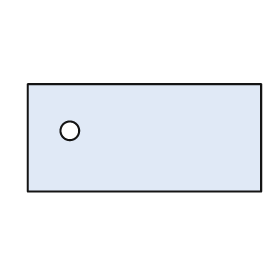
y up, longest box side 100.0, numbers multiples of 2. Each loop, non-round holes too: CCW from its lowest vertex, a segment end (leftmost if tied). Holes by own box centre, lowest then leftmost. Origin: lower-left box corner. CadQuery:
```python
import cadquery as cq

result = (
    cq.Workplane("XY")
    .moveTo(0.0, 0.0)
    .lineTo(100.0, 0.0)
    .lineTo(100.0, 46.0)
    .lineTo(0.0, 46.0)
    .close()
    .moveTo(18.0, 26.0)
    .circle(4.0)
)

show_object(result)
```